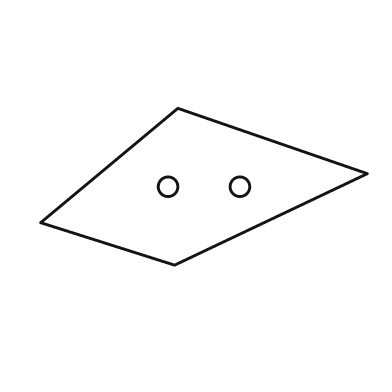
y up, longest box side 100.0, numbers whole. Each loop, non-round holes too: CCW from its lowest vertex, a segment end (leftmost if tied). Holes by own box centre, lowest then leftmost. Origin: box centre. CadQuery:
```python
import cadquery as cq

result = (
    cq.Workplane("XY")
    .moveTo(-9.0, -24.0)
    .lineTo(50.0, 4.0)
    .lineTo(-8.0, 24.0)
    .lineTo(-50.0, -11.0)
    .close()
    .moveTo(-11.0, 0.0)
    .circle(3.0)
    .moveTo(11.0, 0.0)
    .circle(3.0)
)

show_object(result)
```